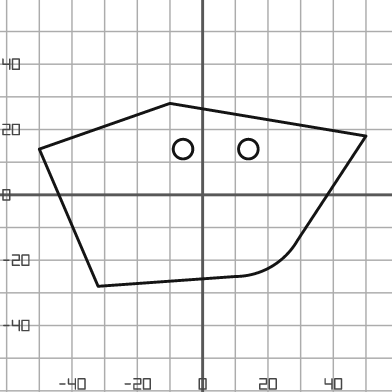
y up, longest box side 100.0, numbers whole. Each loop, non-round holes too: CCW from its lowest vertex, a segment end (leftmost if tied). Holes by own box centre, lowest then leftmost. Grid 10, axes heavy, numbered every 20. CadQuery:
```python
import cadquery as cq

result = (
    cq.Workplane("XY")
    .moveTo(-32.0, -28.0)
    .lineTo(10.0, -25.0)
    .threePointArc((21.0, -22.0), (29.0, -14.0))
    .lineTo(50.0, 18.0)
    .lineTo(-10.0, 28.0)
    .lineTo(-50.0, 14.0)
    .close()
    .moveTo(-6.0, 14.0)
    .circle(3.0)
    .moveTo(14.0, 14.0)
    .circle(3.0)
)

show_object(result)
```